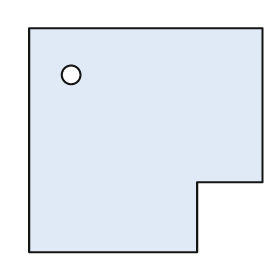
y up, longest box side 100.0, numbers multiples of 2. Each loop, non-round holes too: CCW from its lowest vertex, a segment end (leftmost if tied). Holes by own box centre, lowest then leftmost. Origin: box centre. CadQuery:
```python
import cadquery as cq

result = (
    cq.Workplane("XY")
    .moveTo(-50.0, -48.0)
    .lineTo(22.0, -48.0)
    .lineTo(22.0, -18.0)
    .lineTo(50.0, -18.0)
    .lineTo(50.0, 48.0)
    .lineTo(-50.0, 48.0)
    .close()
    .moveTo(-32.0, 28.0)
    .circle(4.0)
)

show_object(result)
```